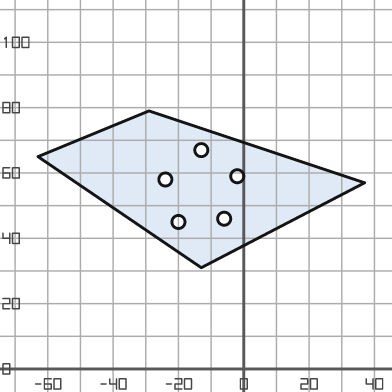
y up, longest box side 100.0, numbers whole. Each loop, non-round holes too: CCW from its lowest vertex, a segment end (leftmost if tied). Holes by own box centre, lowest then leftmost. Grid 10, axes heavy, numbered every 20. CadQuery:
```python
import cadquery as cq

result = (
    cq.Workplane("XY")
    .moveTo(-13.0, 31.0)
    .lineTo(37.0, 57.0)
    .lineTo(-29.0, 79.0)
    .lineTo(-63.0, 65.0)
    .close()
    .moveTo(-20.0, 45.0)
    .circle(2.0)
    .moveTo(-6.0, 46.0)
    .circle(2.0)
    .moveTo(-24.0, 58.0)
    .circle(2.0)
    .moveTo(-2.0, 59.0)
    .circle(2.0)
    .moveTo(-13.0, 67.0)
    .circle(2.0)
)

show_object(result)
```